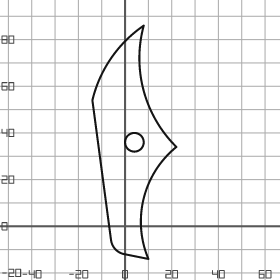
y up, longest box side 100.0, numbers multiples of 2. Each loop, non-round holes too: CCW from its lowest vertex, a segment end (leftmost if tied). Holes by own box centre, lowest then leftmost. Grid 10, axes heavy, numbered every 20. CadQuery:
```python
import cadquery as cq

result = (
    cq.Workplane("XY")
    .moveTo(10.0, -14.0)
    .threePointArc((8.0, 12.0), (22.0, 34.0))
    .threePointArc((8.0, 58.0), (8.0, 86.0))
    .threePointArc((-6.0, 72.0), (-14.0, 54.0))
    .lineTo(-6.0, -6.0)
    .threePointArc((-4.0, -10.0), (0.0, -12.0))
    .close()
    .moveTo(4.0, 36.0)
    .circle(4.0)
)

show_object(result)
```